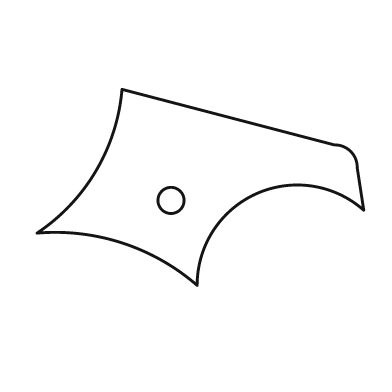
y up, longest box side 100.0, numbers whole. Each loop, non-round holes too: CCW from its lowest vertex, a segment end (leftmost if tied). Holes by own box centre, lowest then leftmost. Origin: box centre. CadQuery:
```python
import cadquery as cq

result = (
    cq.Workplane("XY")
    .moveTo(-1.0, -30.0)
    .threePointArc((17.0, -2.0), (50.0, -7.0))
    .lineTo(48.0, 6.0)
    .threePointArc((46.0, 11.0), (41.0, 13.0))
    .lineTo(-24.0, 30.0)
    .threePointArc((-32.0, 5.0), (-50.0, -14.0))
    .threePointArc((-24.0, -17.0), (-1.0, -30.0))
    .close()
    .moveTo(-9.0, -4.0)
    .circle(4.0)
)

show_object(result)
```